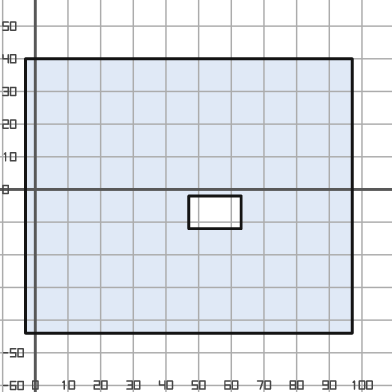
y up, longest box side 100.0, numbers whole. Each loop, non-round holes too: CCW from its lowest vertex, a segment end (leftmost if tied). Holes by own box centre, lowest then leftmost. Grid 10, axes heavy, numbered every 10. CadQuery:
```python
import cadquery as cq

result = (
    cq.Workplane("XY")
    .moveTo(-3.0, -44.0)
    .lineTo(97.0, -44.0)
    .lineTo(97.0, 40.0)
    .lineTo(-3.0, 40.0)
    .close()
    .moveTo(47.0, -12.0)
    .lineTo(63.0, -12.0)
    .lineTo(63.0, -2.0)
    .lineTo(47.0, -2.0)
    .close()
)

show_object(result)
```